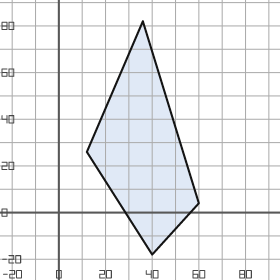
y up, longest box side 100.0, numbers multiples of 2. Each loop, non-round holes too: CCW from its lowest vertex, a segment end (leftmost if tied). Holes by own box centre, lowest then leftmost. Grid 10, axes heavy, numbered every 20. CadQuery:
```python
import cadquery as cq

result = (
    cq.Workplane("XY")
    .moveTo(40.0, -18.0)
    .lineTo(60.0, 4.0)
    .lineTo(36.0, 82.0)
    .lineTo(12.0, 26.0)
    .close()
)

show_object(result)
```